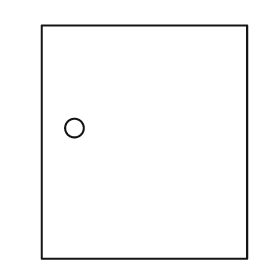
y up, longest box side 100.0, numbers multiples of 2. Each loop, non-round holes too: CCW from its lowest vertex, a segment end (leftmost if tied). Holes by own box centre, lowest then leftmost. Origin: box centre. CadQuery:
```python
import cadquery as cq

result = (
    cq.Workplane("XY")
    .moveTo(-44.0, -50.0)
    .lineTo(44.0, -50.0)
    .lineTo(44.0, 50.0)
    .lineTo(-44.0, 50.0)
    .close()
    .moveTo(-30.0, 6.0)
    .circle(4.0)
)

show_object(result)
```